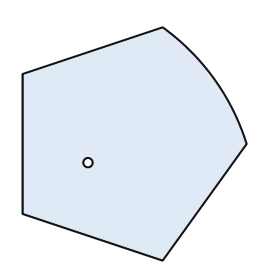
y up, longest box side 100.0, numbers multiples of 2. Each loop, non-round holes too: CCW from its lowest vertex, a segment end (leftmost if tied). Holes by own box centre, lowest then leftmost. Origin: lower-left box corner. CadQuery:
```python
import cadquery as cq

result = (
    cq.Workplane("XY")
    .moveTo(60.0, 0.0)
    .lineTo(96.0, 50.0)
    .threePointArc((82.0, 78.0), (60.0, 100.0))
    .lineTo(0.0, 80.0)
    .lineTo(0.0, 20.0)
    .close()
    .moveTo(28.0, 42.0)
    .circle(2.0)
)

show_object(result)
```